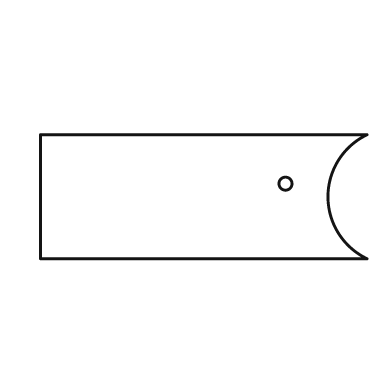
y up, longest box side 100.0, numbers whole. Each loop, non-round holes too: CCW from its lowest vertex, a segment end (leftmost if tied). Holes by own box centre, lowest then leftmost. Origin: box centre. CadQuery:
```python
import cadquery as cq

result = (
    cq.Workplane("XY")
    .moveTo(-50.0, -19.0)
    .lineTo(50.0, -19.0)
    .threePointArc((38.0, 0.0), (50.0, 19.0))
    .lineTo(-50.0, 19.0)
    .close()
    .moveTo(25.0, 4.0)
    .circle(2.0)
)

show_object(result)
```